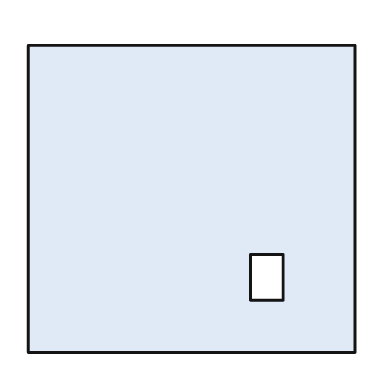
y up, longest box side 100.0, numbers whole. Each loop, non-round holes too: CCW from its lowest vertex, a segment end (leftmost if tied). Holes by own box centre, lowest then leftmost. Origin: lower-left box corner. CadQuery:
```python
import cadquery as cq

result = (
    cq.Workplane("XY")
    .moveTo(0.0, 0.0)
    .lineTo(100.0, 0.0)
    .lineTo(100.0, 94.0)
    .lineTo(0.0, 94.0)
    .close()
    .moveTo(68.0, 16.0)
    .lineTo(78.0, 16.0)
    .lineTo(78.0, 30.0)
    .lineTo(68.0, 30.0)
    .close()
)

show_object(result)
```